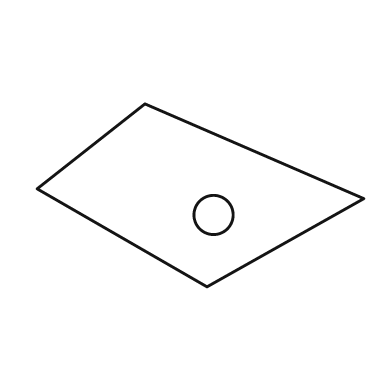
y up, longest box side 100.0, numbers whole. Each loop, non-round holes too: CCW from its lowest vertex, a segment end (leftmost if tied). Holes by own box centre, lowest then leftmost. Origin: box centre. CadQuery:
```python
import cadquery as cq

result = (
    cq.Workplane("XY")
    .moveTo(2.0, -28.0)
    .lineTo(50.0, -1.0)
    .lineTo(-17.0, 28.0)
    .lineTo(-50.0, 2.0)
    .close()
    .moveTo(4.0, -6.0)
    .circle(6.0)
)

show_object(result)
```